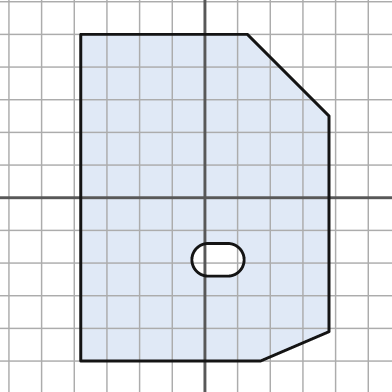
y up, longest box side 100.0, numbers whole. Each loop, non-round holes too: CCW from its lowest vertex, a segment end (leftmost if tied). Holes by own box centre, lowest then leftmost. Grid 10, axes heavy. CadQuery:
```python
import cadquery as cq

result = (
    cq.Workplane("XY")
    .moveTo(-38.0, -50.0)
    .lineTo(17.0, -50.0)
    .lineTo(38.0, -41.0)
    .lineTo(38.0, 25.0)
    .lineTo(13.0, 50.0)
    .lineTo(-38.0, 50.0)
    .close()
    .moveTo(1.0, -24.0)
    .lineTo(7.0, -24.0)
    .threePointArc((12.0, -19.0), (7.0, -14.0))
    .lineTo(1.0, -14.0)
    .threePointArc((-4.0, -19.0), (1.0, -24.0))
    .close()
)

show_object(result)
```